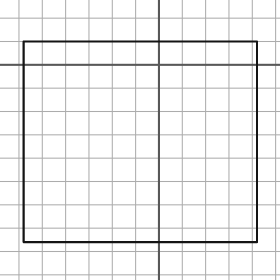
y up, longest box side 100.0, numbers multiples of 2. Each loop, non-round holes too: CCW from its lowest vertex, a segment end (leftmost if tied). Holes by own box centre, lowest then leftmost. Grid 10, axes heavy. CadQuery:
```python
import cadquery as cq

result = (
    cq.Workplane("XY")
    .moveTo(-58.0, -76.0)
    .lineTo(42.0, -76.0)
    .lineTo(42.0, 10.0)
    .lineTo(-58.0, 10.0)
    .close()
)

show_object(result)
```